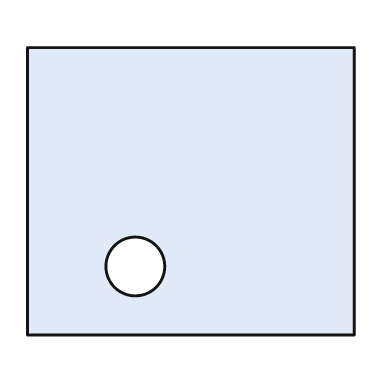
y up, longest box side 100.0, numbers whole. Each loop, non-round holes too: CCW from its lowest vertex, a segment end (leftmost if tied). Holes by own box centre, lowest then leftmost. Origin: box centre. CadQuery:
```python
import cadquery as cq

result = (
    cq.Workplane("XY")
    .moveTo(-50.0, -44.0)
    .lineTo(50.0, -44.0)
    .lineTo(50.0, 44.0)
    .lineTo(-50.0, 44.0)
    .close()
    .moveTo(-17.0, -23.0)
    .circle(9.0)
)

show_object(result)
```